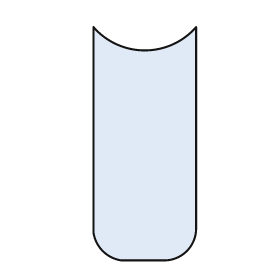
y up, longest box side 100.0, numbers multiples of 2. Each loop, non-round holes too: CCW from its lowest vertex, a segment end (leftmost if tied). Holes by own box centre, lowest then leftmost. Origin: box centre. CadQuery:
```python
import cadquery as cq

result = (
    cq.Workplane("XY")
    .moveTo(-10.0, -50.0)
    .lineTo(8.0, -50.0)
    .threePointArc((18.0, -46.0), (22.0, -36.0))
    .lineTo(22.0, 50.0)
    .threePointArc((0.0, 40.0), (-22.0, 50.0))
    .lineTo(-22.0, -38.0)
    .threePointArc((-18.0, -46.0), (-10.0, -50.0))
    .close()
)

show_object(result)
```